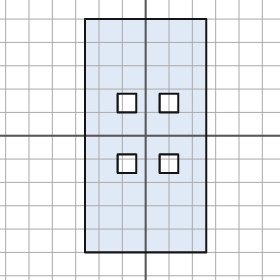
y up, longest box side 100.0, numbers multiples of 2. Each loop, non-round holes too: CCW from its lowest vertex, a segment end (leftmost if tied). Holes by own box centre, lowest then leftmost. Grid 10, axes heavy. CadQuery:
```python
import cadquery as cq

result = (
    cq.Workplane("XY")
    .moveTo(-26.0, -50.0)
    .lineTo(26.0, -50.0)
    .lineTo(26.0, 50.0)
    .lineTo(-26.0, 50.0)
    .close()
    .moveTo(-12.0, -16.0)
    .lineTo(-4.0, -16.0)
    .lineTo(-4.0, -8.0)
    .lineTo(-12.0, -8.0)
    .close()
    .moveTo(6.0, -16.0)
    .lineTo(14.0, -16.0)
    .lineTo(14.0, -8.0)
    .lineTo(6.0, -8.0)
    .close()
    .moveTo(-12.0, 10.0)
    .lineTo(-4.0, 10.0)
    .lineTo(-4.0, 18.0)
    .lineTo(-12.0, 18.0)
    .close()
    .moveTo(6.0, 10.0)
    .lineTo(14.0, 10.0)
    .lineTo(14.0, 18.0)
    .lineTo(6.0, 18.0)
    .close()
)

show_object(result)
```